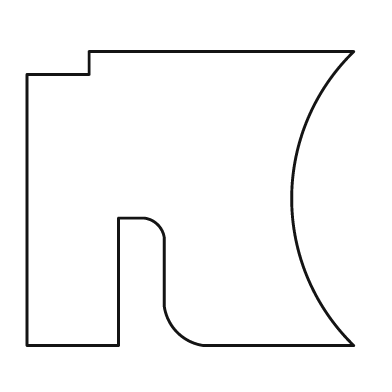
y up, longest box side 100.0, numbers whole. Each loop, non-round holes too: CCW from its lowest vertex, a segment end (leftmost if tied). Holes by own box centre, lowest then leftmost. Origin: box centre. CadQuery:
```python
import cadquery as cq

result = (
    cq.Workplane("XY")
    .moveTo(-50.0, -45.0)
    .lineTo(-22.0, -45.0)
    .lineTo(-22.0, -6.0)
    .lineTo(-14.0, -6.0)
    .threePointArc((-10.0, -8.0), (-8.0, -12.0))
    .lineTo(-8.0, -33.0)
    .threePointArc((-4.0, -41.0), (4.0, -45.0))
    .lineTo(50.0, -45.0)
    .threePointArc((31.0, 0.0), (50.0, 45.0))
    .lineTo(-31.0, 45.0)
    .lineTo(-31.0, 38.0)
    .lineTo(-50.0, 38.0)
    .close()
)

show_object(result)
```